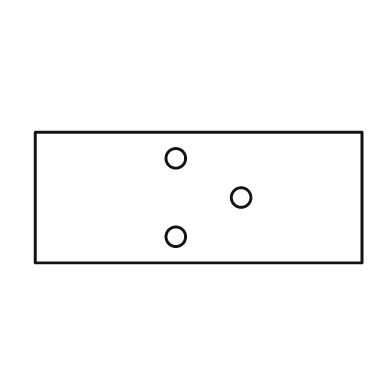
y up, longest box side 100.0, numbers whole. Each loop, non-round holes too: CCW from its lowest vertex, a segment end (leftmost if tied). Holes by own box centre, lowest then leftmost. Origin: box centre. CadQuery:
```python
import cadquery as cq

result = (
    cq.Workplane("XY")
    .moveTo(-50.0, -20.0)
    .lineTo(50.0, -20.0)
    .lineTo(50.0, 20.0)
    .lineTo(-50.0, 20.0)
    .close()
    .moveTo(-7.0, -12.0)
    .circle(3.0)
    .moveTo(13.0, 0.0)
    .circle(3.0)
    .moveTo(-7.0, 12.0)
    .circle(3.0)
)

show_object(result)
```